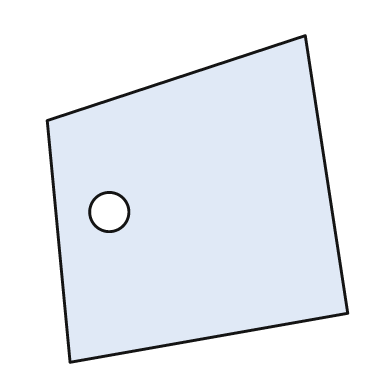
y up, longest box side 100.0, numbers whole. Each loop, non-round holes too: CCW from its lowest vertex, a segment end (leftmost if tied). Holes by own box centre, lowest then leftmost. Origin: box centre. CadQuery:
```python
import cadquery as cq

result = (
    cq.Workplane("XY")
    .moveTo(-39.0, -50.0)
    .lineTo(46.0, -35.0)
    .lineTo(33.0, 50.0)
    .lineTo(-46.0, 24.0)
    .close()
    .moveTo(-27.0, -4.0)
    .circle(6.0)
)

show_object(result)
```